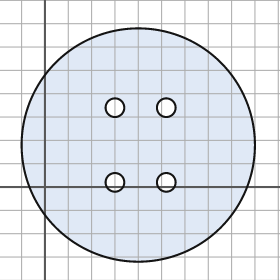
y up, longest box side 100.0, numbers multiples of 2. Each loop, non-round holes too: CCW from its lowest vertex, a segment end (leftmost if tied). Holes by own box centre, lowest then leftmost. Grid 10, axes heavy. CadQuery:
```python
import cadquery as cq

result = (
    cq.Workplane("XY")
    .moveTo(40.0, 18.0)
    .circle(50.0)
    .moveTo(30.0, 2.0)
    .circle(4.0)
    .moveTo(52.0, 2.0)
    .circle(4.0)
    .moveTo(30.0, 34.0)
    .circle(4.0)
    .moveTo(52.0, 34.0)
    .circle(4.0)
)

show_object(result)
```